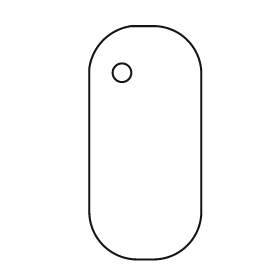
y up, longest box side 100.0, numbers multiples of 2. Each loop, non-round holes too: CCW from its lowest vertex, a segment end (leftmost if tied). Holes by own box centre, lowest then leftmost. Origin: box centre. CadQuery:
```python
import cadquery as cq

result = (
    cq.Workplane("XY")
    .moveTo(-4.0, -50.0)
    .lineTo(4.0, -50.0)
    .threePointArc((18.0, -44.0), (24.0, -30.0))
    .lineTo(24.0, 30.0)
    .threePointArc((18.0, 44.0), (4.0, 50.0))
    .lineTo(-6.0, 50.0)
    .threePointArc((-18.0, 44.0), (-24.0, 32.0))
    .lineTo(-24.0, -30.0)
    .threePointArc((-18.0, -44.0), (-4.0, -50.0))
    .close()
    .moveTo(-10.0, 30.0)
    .circle(4.0)
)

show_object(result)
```